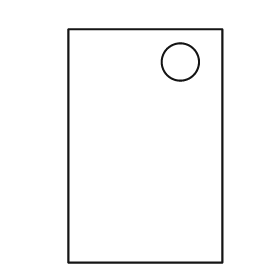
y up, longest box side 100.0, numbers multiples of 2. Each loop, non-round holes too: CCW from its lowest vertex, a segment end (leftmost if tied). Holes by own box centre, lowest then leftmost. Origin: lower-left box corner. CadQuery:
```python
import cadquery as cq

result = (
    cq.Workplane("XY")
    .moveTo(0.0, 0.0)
    .lineTo(66.0, 0.0)
    .lineTo(66.0, 100.0)
    .lineTo(0.0, 100.0)
    .close()
    .moveTo(48.0, 86.0)
    .circle(8.0)
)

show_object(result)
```